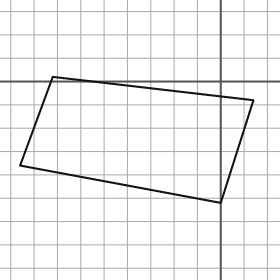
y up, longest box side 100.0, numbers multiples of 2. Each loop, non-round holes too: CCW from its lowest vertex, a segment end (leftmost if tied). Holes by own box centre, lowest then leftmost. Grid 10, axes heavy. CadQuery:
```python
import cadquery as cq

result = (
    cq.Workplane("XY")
    .moveTo(0.0, -52.0)
    .lineTo(14.0, -8.0)
    .lineTo(-72.0, 2.0)
    .lineTo(-86.0, -36.0)
    .close()
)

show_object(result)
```